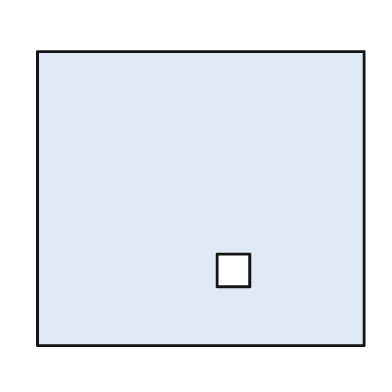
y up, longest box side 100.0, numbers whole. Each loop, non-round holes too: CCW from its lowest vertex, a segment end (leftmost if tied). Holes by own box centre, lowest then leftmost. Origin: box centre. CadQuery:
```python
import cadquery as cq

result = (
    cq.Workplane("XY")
    .moveTo(-50.0, -45.0)
    .lineTo(50.0, -45.0)
    .lineTo(50.0, 45.0)
    .lineTo(-50.0, 45.0)
    .close()
    .moveTo(5.0, -27.0)
    .lineTo(15.0, -27.0)
    .lineTo(15.0, -17.0)
    .lineTo(5.0, -17.0)
    .close()
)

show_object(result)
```